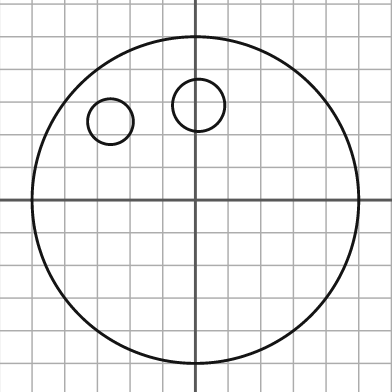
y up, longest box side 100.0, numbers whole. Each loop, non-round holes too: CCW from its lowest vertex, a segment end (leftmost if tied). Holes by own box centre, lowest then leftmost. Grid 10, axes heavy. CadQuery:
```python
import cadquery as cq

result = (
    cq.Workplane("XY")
    .moveTo(0.0, 0.0)
    .circle(50.0)
    .moveTo(-26.0, 24.0)
    .circle(7.0)
    .moveTo(1.0, 29.0)
    .circle(8.0)
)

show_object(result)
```